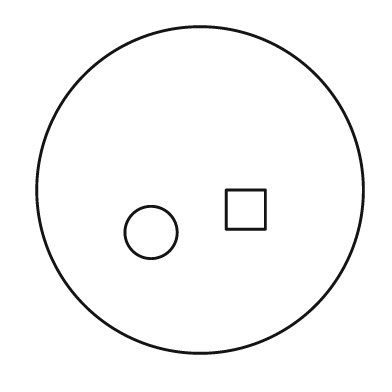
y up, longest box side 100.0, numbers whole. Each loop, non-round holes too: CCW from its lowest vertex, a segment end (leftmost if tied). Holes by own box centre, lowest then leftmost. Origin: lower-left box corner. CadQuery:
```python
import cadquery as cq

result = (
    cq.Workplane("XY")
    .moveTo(50.0, 50.0)
    .circle(50.0)
    .moveTo(35.0, 37.0)
    .circle(8.0)
    .moveTo(58.0, 38.0)
    .lineTo(70.0, 38.0)
    .lineTo(70.0, 50.0)
    .lineTo(58.0, 50.0)
    .close()
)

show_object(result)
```